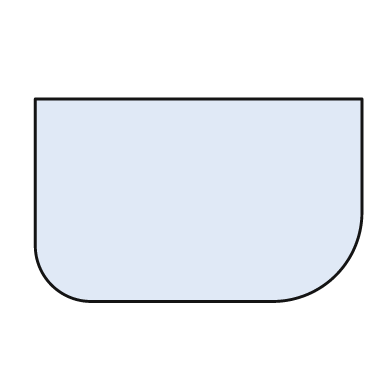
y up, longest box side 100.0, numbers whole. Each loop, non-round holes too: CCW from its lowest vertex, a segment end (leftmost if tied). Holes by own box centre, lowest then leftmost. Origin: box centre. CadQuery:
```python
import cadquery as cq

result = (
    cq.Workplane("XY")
    .moveTo(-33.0, -31.0)
    .lineTo(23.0, -31.0)
    .threePointArc((42.0, -23.0), (50.0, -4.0))
    .lineTo(50.0, 31.0)
    .lineTo(-50.0, 31.0)
    .lineTo(-50.0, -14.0)
    .threePointArc((-45.0, -26.0), (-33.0, -31.0))
    .close()
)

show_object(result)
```